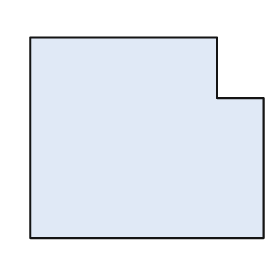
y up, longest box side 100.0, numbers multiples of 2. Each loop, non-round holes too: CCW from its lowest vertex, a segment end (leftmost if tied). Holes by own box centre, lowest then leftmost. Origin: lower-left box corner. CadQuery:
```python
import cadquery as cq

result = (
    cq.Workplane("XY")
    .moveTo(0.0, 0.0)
    .lineTo(100.0, 0.0)
    .lineTo(100.0, 60.0)
    .lineTo(80.0, 60.0)
    .lineTo(80.0, 86.0)
    .lineTo(0.0, 86.0)
    .close()
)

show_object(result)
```